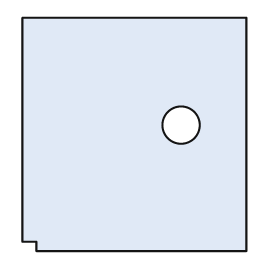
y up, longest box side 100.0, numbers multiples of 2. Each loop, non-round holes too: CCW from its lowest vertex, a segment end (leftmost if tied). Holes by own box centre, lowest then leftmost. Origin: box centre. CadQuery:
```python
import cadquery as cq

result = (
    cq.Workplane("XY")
    .moveTo(-42.0, -50.0)
    .lineTo(48.0, -50.0)
    .lineTo(48.0, 50.0)
    .lineTo(-48.0, 50.0)
    .lineTo(-48.0, -46.0)
    .lineTo(-42.0, -46.0)
    .close()
    .moveTo(20.0, 4.0)
    .circle(8.0)
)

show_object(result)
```